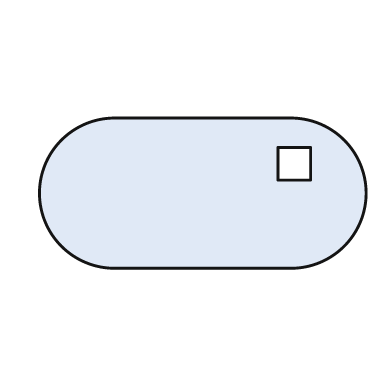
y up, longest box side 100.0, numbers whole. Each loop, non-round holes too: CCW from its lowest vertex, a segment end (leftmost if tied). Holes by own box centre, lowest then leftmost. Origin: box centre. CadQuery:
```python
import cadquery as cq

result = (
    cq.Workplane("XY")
    .moveTo(-27.0, -23.0)
    .lineTo(27.0, -23.0)
    .threePointArc((50.0, 0.0), (27.0, 23.0))
    .lineTo(-27.0, 23.0)
    .threePointArc((-50.0, 0.0), (-27.0, -23.0))
    .close()
    .moveTo(23.0, 4.0)
    .lineTo(33.0, 4.0)
    .lineTo(33.0, 14.0)
    .lineTo(23.0, 14.0)
    .close()
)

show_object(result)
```